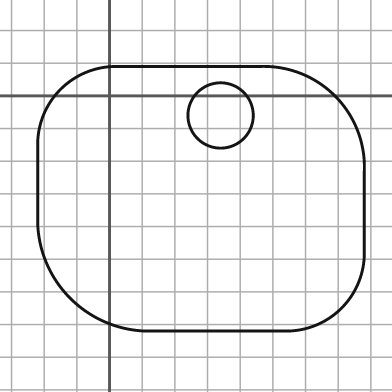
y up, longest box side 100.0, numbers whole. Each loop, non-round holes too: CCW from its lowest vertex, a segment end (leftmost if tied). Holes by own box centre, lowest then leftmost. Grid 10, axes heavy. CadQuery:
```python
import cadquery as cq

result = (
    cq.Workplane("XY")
    .moveTo(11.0, -72.0)
    .lineTo(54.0, -72.0)
    .threePointArc((71.0, -65.0), (78.0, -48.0))
    .lineTo(78.0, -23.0)
    .threePointArc((69.0, 0.0), (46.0, 9.0))
    .lineTo(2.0, 9.0)
    .threePointArc((-15.0, 2.0), (-22.0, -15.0))
    .lineTo(-22.0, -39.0)
    .threePointArc((-12.0, -62.0), (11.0, -72.0))
    .close()
    .moveTo(34.0, -6.0)
    .circle(10.0)
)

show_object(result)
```